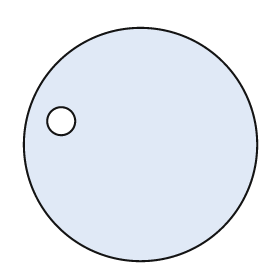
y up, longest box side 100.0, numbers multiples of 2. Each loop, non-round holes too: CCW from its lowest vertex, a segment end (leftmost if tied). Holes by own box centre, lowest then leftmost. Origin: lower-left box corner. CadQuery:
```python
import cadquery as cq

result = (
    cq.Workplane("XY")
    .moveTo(50.0, 50.0)
    .circle(50.0)
    .moveTo(16.0, 60.0)
    .circle(6.0)
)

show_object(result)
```